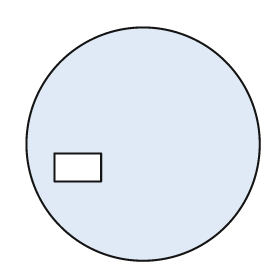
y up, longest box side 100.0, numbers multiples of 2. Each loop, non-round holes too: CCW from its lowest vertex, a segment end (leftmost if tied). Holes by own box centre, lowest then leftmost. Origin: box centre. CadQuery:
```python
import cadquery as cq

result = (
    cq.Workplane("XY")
    .moveTo(0.0, 0.0)
    .circle(50.0)
    .moveTo(-38.0, -16.0)
    .lineTo(-18.0, -16.0)
    .lineTo(-18.0, -4.0)
    .lineTo(-38.0, -4.0)
    .close()
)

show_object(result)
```